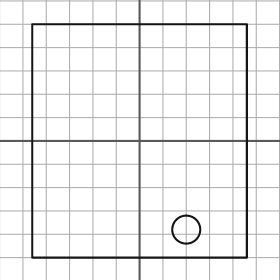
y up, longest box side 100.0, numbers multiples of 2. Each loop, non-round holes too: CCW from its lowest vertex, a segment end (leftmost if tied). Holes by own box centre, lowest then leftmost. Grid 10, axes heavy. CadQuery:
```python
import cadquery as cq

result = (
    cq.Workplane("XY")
    .moveTo(-46.0, -50.0)
    .lineTo(46.0, -50.0)
    .lineTo(46.0, 50.0)
    .lineTo(-46.0, 50.0)
    .close()
    .moveTo(20.0, -38.0)
    .circle(6.0)
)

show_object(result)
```